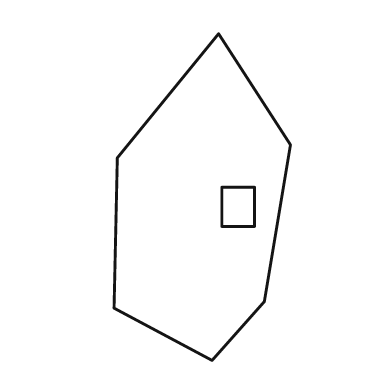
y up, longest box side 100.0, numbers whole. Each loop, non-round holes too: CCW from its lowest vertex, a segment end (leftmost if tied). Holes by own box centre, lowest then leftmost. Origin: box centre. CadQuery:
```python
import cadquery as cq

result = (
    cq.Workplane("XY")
    .moveTo(3.0, -50.0)
    .lineTo(19.0, -32.0)
    .lineTo(27.0, 16.0)
    .lineTo(5.0, 50.0)
    .lineTo(-26.0, 12.0)
    .lineTo(-27.0, -34.0)
    .close()
    .moveTo(6.0, -9.0)
    .lineTo(16.0, -9.0)
    .lineTo(16.0, 3.0)
    .lineTo(6.0, 3.0)
    .close()
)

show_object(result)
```